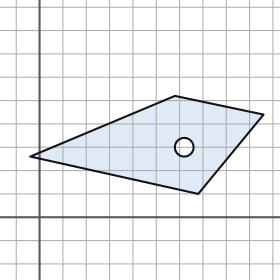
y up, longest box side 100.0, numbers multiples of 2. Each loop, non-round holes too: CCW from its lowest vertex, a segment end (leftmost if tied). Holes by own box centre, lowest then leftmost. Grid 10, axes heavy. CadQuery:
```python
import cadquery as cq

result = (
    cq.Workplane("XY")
    .moveTo(68.0, 10.0)
    .lineTo(96.0, 44.0)
    .lineTo(58.0, 52.0)
    .lineTo(-4.0, 26.0)
    .close()
    .moveTo(62.0, 30.0)
    .circle(4.0)
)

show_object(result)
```